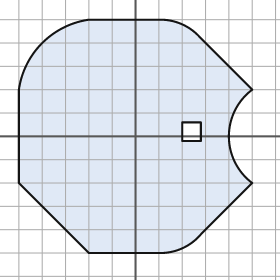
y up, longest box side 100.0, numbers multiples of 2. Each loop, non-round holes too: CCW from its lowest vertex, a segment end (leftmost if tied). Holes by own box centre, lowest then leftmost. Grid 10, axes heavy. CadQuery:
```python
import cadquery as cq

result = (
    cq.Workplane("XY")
    .moveTo(-20.0, -50.0)
    .lineTo(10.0, -50.0)
    .threePointArc((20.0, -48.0), (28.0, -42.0))
    .lineTo(50.0, -20.0)
    .threePointArc((40.0, 0.0), (50.0, 20.0))
    .lineTo(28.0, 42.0)
    .threePointArc((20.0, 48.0), (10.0, 50.0))
    .lineTo(-20.0, 50.0)
    .threePointArc((-40.0, 40.0), (-50.0, 20.0))
    .lineTo(-50.0, -20.0)
    .close()
    .moveTo(20.0, -2.0)
    .lineTo(28.0, -2.0)
    .lineTo(28.0, 6.0)
    .lineTo(20.0, 6.0)
    .close()
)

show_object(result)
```